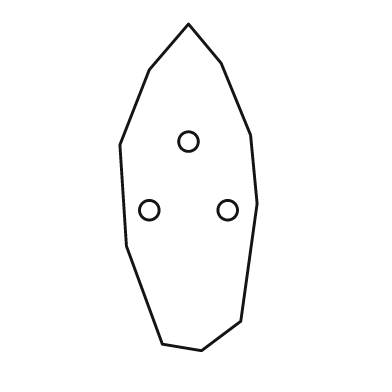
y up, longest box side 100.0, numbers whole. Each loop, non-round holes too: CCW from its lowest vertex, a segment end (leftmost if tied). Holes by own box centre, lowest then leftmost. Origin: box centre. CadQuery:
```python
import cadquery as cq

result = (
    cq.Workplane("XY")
    .moveTo(4.0, -50.0)
    .lineTo(16.0, -41.0)
    .lineTo(21.0, -5.0)
    .lineTo(19.0, 16.0)
    .lineTo(10.0, 38.0)
    .lineTo(0.0, 50.0)
    .lineTo(-12.0, 36.0)
    .lineTo(-21.0, 13.0)
    .lineTo(-19.0, -18.0)
    .lineTo(-8.0, -48.0)
    .close()
    .moveTo(-12.0, -7.0)
    .circle(3.0)
    .moveTo(12.0, -7.0)
    .circle(3.0)
    .moveTo(0.0, 14.0)
    .circle(3.0)
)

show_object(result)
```